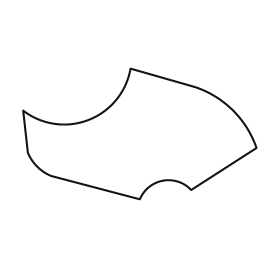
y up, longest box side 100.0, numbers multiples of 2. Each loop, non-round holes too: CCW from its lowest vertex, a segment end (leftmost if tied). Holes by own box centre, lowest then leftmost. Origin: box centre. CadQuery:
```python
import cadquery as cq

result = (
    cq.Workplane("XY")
    .moveTo(0.0, -28.0)
    .threePointArc((10.0, -20.0), (22.0, -24.0))
    .lineTo(50.0, -6.0)
    .threePointArc((40.0, 10.0), (24.0, 20.0))
    .lineTo(-4.0, 28.0)
    .threePointArc((-22.0, 6.0), (-50.0, 10.0))
    .lineTo(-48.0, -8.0)
    .threePointArc((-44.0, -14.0), (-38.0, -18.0))
    .close()
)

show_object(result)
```